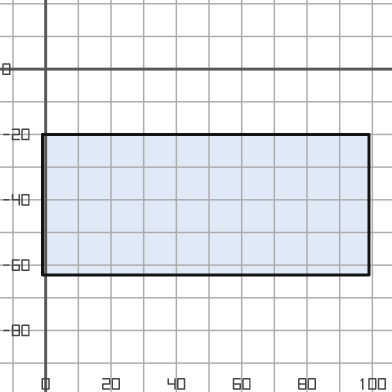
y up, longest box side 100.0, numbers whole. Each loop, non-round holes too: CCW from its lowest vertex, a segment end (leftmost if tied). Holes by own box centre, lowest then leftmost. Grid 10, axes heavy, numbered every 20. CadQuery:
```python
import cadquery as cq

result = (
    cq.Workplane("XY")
    .moveTo(-1.0, -63.0)
    .lineTo(99.0, -63.0)
    .lineTo(99.0, -20.0)
    .lineTo(-1.0, -20.0)
    .close()
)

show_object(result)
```